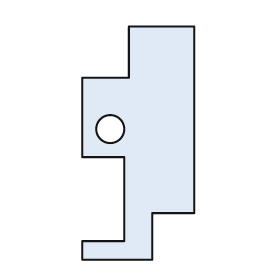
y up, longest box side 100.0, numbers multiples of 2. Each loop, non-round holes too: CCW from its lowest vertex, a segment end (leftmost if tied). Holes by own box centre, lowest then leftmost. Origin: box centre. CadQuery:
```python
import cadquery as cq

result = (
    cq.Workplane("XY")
    .moveTo(-24.0, -50.0)
    .lineTo(6.0, -50.0)
    .lineTo(6.0, -30.0)
    .lineTo(24.0, -30.0)
    .lineTo(24.0, 50.0)
    .lineTo(-4.0, 50.0)
    .lineTo(-4.0, 28.0)
    .lineTo(-24.0, 28.0)
    .lineTo(-24.0, -6.0)
    .lineTo(-6.0, -6.0)
    .lineTo(-6.0, -42.0)
    .lineTo(-24.0, -42.0)
    .close()
    .moveTo(-12.0, 6.0)
    .circle(6.0)
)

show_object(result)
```